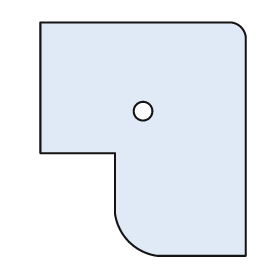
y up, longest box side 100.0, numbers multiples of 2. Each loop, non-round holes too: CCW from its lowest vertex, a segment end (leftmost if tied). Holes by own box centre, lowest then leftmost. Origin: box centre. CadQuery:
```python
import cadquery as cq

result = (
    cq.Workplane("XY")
    .moveTo(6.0, -50.0)
    .lineTo(44.0, -50.0)
    .lineTo(44.0, 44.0)
    .threePointArc((42.0, 48.0), (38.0, 50.0))
    .lineTo(-44.0, 50.0)
    .lineTo(-44.0, -6.0)
    .lineTo(-12.0, -6.0)
    .lineTo(-12.0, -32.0)
    .threePointArc((-6.0, -44.0), (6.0, -50.0))
    .close()
    .moveTo(0.0, 12.0)
    .circle(4.0)
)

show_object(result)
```